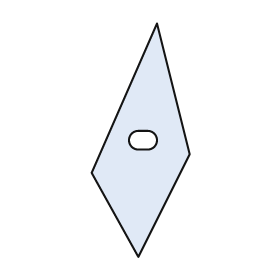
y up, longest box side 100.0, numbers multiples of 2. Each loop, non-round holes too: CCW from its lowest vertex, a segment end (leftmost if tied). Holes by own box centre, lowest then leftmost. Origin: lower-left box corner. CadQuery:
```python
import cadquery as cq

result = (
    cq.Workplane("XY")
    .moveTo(20.0, 0.0)
    .lineTo(42.0, 44.0)
    .lineTo(28.0, 100.0)
    .lineTo(0.0, 36.0)
    .close()
    .moveTo(20.0, 46.0)
    .lineTo(24.0, 46.0)
    .threePointArc((28.0, 50.0), (24.0, 54.0))
    .lineTo(20.0, 54.0)
    .threePointArc((16.0, 50.0), (20.0, 46.0))
    .close()
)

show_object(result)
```